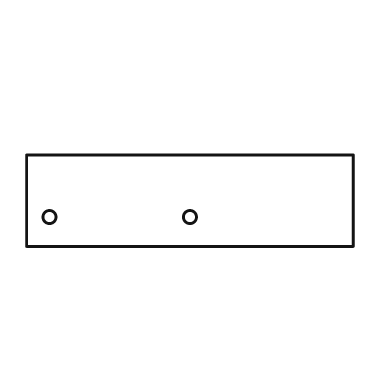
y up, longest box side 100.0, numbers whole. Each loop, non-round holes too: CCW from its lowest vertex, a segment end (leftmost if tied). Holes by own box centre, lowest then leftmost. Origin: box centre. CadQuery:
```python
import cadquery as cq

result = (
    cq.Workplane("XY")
    .moveTo(-50.0, -14.0)
    .lineTo(50.0, -14.0)
    .lineTo(50.0, 14.0)
    .lineTo(-50.0, 14.0)
    .close()
    .moveTo(-43.0, -5.0)
    .circle(2.0)
    .moveTo(0.0, -5.0)
    .circle(2.0)
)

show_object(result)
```